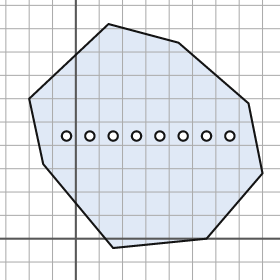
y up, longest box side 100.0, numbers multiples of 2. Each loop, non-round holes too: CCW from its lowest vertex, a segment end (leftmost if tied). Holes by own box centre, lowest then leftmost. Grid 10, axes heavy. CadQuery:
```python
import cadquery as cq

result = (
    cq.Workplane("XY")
    .moveTo(16.0, -4.0)
    .lineTo(56.0, 0.0)
    .lineTo(80.0, 28.0)
    .lineTo(74.0, 58.0)
    .lineTo(44.0, 84.0)
    .lineTo(14.0, 92.0)
    .lineTo(-20.0, 60.0)
    .lineTo(-14.0, 32.0)
    .close()
    .moveTo(-4.0, 44.0)
    .circle(2.0)
    .moveTo(6.0, 44.0)
    .circle(2.0)
    .moveTo(16.0, 44.0)
    .circle(2.0)
    .moveTo(26.0, 44.0)
    .circle(2.0)
    .moveTo(36.0, 44.0)
    .circle(2.0)
    .moveTo(46.0, 44.0)
    .circle(2.0)
    .moveTo(56.0, 44.0)
    .circle(2.0)
    .moveTo(66.0, 44.0)
    .circle(2.0)
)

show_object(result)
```